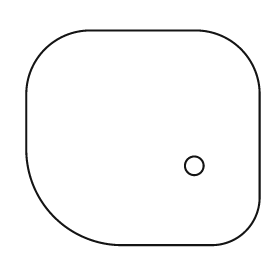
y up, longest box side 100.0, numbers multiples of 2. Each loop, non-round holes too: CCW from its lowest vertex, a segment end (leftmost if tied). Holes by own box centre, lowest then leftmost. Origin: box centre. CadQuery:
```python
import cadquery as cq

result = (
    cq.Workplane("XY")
    .moveTo(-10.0, -46.0)
    .lineTo(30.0, -46.0)
    .threePointArc((44.0, -40.0), (50.0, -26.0))
    .lineTo(50.0, 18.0)
    .threePointArc((42.0, 38.0), (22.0, 46.0))
    .lineTo(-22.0, 46.0)
    .threePointArc((-42.0, 38.0), (-50.0, 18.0))
    .lineTo(-50.0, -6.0)
    .threePointArc((-38.0, -34.0), (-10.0, -46.0))
    .close()
    .moveTo(22.0, -12.0)
    .circle(4.0)
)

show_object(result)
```